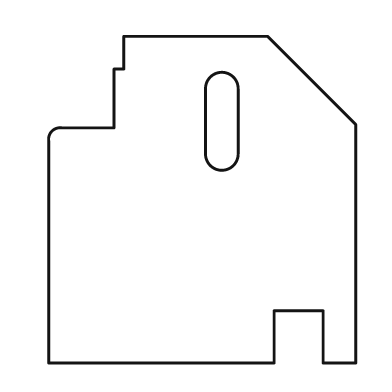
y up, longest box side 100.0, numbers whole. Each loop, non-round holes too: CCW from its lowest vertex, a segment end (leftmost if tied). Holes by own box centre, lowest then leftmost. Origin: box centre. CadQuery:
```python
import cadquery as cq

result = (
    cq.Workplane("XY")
    .moveTo(-47.0, -50.0)
    .lineTo(22.0, -50.0)
    .lineTo(22.0, -34.0)
    .lineTo(37.0, -34.0)
    .lineTo(37.0, -50.0)
    .lineTo(47.0, -50.0)
    .lineTo(47.0, 23.0)
    .lineTo(20.0, 50.0)
    .lineTo(-24.0, 50.0)
    .lineTo(-24.0, 40.0)
    .lineTo(-27.0, 40.0)
    .lineTo(-27.0, 22.0)
    .lineTo(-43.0, 22.0)
    .threePointArc((-46.0, 21.0), (-47.0, 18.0))
    .close()
    .moveTo(1.0, 14.0)
    .threePointArc((6.0, 9.0), (11.0, 14.0))
    .lineTo(11.0, 34.0)
    .threePointArc((6.0, 39.0), (1.0, 34.0))
    .close()
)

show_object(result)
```